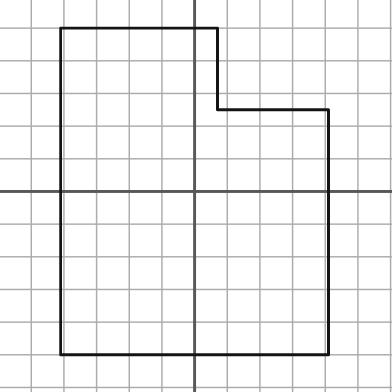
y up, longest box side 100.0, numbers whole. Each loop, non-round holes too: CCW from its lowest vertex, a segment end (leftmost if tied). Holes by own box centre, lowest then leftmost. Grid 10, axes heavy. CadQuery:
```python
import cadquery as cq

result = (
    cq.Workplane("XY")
    .moveTo(-41.0, -50.0)
    .lineTo(41.0, -50.0)
    .lineTo(41.0, 25.0)
    .lineTo(7.0, 25.0)
    .lineTo(7.0, 50.0)
    .lineTo(-41.0, 50.0)
    .close()
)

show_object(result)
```